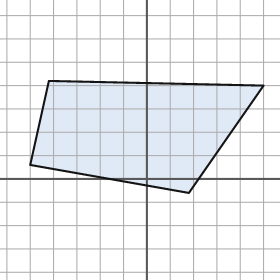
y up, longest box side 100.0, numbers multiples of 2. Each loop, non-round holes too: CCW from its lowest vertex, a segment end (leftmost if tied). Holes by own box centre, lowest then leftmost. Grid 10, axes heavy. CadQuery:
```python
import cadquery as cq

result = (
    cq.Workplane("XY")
    .moveTo(18.0, -6.0)
    .lineTo(50.0, 40.0)
    .lineTo(-42.0, 42.0)
    .lineTo(-50.0, 6.0)
    .close()
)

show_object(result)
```